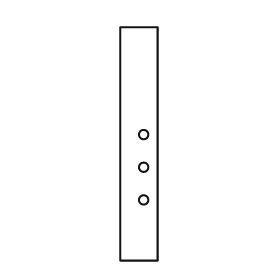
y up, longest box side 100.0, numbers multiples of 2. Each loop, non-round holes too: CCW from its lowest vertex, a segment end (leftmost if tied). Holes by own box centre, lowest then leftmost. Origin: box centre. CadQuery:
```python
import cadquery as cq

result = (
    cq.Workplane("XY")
    .moveTo(-8.0, -50.0)
    .lineTo(8.0, -50.0)
    .lineTo(8.0, 50.0)
    .lineTo(-8.0, 50.0)
    .close()
    .moveTo(2.0, -24.0)
    .circle(2.0)
    .moveTo(2.0, -10.0)
    .circle(2.0)
    .moveTo(2.0, 4.0)
    .circle(2.0)
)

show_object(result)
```